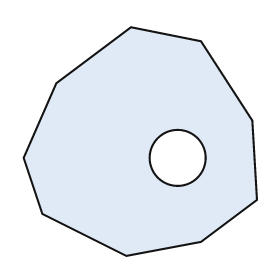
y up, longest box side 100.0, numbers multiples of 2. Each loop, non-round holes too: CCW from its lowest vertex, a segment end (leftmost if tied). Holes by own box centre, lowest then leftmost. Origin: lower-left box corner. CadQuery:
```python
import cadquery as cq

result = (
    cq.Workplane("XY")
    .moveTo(44.0, 0.0)
    .lineTo(76.0, 6.0)
    .lineTo(100.0, 24.0)
    .lineTo(98.0, 58.0)
    .lineTo(76.0, 92.0)
    .lineTo(46.0, 98.0)
    .lineTo(14.0, 74.0)
    .lineTo(0.0, 42.0)
    .lineTo(8.0, 18.0)
    .close()
    .moveTo(66.0, 42.0)
    .circle(12.0)
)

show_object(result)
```